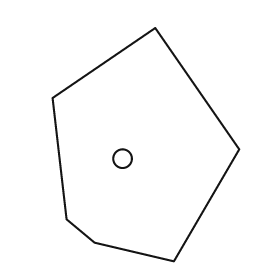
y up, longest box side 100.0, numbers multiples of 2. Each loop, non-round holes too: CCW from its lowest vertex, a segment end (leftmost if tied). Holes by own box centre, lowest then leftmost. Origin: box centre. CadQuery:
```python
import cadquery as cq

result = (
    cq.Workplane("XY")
    .moveTo(12.0, -50.0)
    .lineTo(40.0, -2.0)
    .lineTo(4.0, 50.0)
    .lineTo(-40.0, 20.0)
    .lineTo(-34.0, -32.0)
    .lineTo(-22.0, -42.0)
    .close()
    .moveTo(-10.0, -6.0)
    .circle(4.0)
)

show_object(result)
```